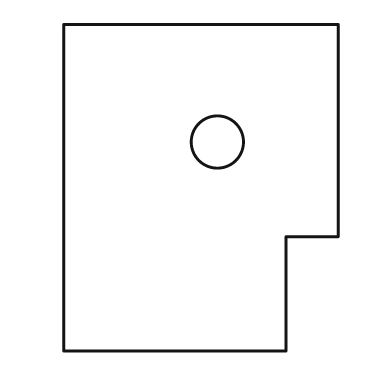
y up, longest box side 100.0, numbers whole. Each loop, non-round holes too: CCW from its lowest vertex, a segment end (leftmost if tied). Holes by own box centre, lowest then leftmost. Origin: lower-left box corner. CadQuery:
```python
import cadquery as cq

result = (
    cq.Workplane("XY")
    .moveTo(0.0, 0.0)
    .lineTo(68.0, 0.0)
    .lineTo(68.0, 35.0)
    .lineTo(84.0, 35.0)
    .lineTo(84.0, 100.0)
    .lineTo(0.0, 100.0)
    .close()
    .moveTo(47.0, 64.0)
    .circle(8.0)
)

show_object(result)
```